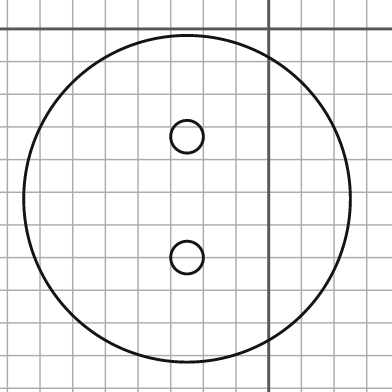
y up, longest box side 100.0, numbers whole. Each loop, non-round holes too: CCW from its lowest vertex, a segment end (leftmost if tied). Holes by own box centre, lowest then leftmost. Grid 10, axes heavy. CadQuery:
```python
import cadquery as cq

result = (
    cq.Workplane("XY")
    .moveTo(-25.0, -52.0)
    .circle(50.0)
    .moveTo(-25.0, -70.0)
    .circle(5.0)
    .moveTo(-25.0, -33.0)
    .circle(5.0)
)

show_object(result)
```